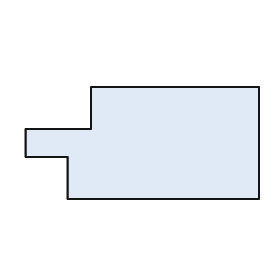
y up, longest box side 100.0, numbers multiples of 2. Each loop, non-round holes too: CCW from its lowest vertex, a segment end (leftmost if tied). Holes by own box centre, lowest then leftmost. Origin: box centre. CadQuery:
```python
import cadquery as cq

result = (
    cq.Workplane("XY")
    .moveTo(-32.0, -24.0)
    .lineTo(50.0, -24.0)
    .lineTo(50.0, 24.0)
    .lineTo(-22.0, 24.0)
    .lineTo(-22.0, 6.0)
    .lineTo(-50.0, 6.0)
    .lineTo(-50.0, -6.0)
    .lineTo(-32.0, -6.0)
    .close()
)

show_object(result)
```